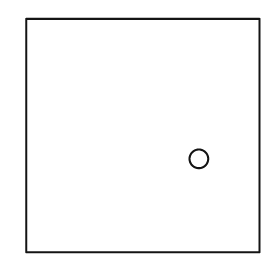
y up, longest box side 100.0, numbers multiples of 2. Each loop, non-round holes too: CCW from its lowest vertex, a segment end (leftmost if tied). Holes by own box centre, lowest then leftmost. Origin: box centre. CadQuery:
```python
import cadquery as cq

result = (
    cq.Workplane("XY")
    .moveTo(-50.0, -50.0)
    .lineTo(50.0, -50.0)
    .lineTo(50.0, 50.0)
    .lineTo(-50.0, 50.0)
    .close()
    .moveTo(24.0, -10.0)
    .circle(4.0)
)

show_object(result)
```